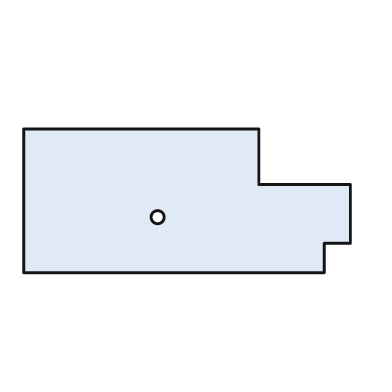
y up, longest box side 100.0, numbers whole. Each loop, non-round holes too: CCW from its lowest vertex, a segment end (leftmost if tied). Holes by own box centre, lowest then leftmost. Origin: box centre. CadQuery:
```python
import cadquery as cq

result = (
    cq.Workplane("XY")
    .moveTo(-50.0, -22.0)
    .lineTo(42.0, -22.0)
    .lineTo(42.0, -13.0)
    .lineTo(50.0, -13.0)
    .lineTo(50.0, 5.0)
    .lineTo(22.0, 5.0)
    .lineTo(22.0, 22.0)
    .lineTo(-50.0, 22.0)
    .close()
    .moveTo(-9.0, -5.0)
    .circle(2.0)
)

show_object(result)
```